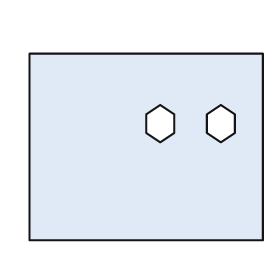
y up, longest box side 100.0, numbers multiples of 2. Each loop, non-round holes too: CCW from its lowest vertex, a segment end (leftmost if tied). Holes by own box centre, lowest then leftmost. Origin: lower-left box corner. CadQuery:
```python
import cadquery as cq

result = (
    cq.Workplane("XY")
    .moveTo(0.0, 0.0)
    .lineTo(100.0, 0.0)
    .lineTo(100.0, 80.0)
    .lineTo(0.0, 80.0)
    .close()
    .moveTo(56.0, 42.0)
    .lineTo(62.0, 46.0)
    .lineTo(62.0, 54.0)
    .lineTo(56.0, 58.0)
    .lineTo(50.0, 54.0)
    .lineTo(50.0, 46.0)
    .close()
    .moveTo(82.0, 42.0)
    .lineTo(88.0, 46.0)
    .lineTo(88.0, 54.0)
    .lineTo(82.0, 58.0)
    .lineTo(76.0, 54.0)
    .lineTo(76.0, 46.0)
    .close()
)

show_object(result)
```